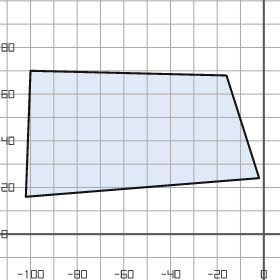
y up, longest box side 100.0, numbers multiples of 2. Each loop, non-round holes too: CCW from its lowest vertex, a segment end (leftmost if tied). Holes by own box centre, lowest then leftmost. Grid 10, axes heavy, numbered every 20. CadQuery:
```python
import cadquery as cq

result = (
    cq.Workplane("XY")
    .moveTo(-102.0, 16.0)
    .lineTo(-2.0, 24.0)
    .lineTo(-16.0, 68.0)
    .lineTo(-100.0, 70.0)
    .close()
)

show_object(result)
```